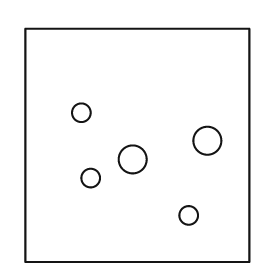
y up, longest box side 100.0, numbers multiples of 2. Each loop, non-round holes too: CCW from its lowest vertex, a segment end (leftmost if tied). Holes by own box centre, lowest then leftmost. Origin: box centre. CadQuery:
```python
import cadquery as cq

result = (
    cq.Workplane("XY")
    .moveTo(-48.0, -50.0)
    .lineTo(48.0, -50.0)
    .lineTo(48.0, 50.0)
    .lineTo(-48.0, 50.0)
    .close()
    .moveTo(22.0, -30.0)
    .circle(4.0)
    .moveTo(-20.0, -14.0)
    .circle(4.0)
    .moveTo(-2.0, -6.0)
    .circle(6.0)
    .moveTo(30.0, 2.0)
    .circle(6.0)
    .moveTo(-24.0, 14.0)
    .circle(4.0)
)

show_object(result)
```